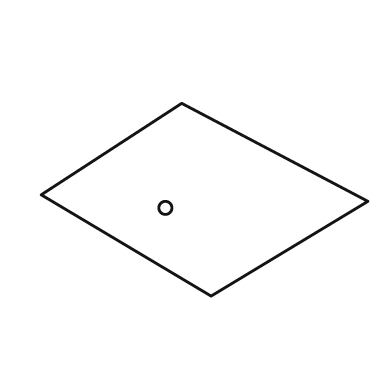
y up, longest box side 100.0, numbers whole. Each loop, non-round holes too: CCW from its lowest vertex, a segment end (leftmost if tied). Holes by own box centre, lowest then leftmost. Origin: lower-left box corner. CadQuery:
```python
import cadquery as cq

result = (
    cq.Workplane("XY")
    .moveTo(52.0, 0.0)
    .lineTo(100.0, 29.0)
    .lineTo(43.0, 59.0)
    .lineTo(0.0, 31.0)
    .close()
    .moveTo(38.0, 27.0)
    .circle(2.0)
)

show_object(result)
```